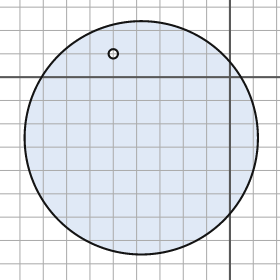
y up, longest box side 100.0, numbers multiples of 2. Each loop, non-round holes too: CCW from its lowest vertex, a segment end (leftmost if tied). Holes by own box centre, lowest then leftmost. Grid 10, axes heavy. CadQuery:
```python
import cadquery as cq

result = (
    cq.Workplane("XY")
    .moveTo(-38.0, -26.0)
    .circle(50.0)
    .moveTo(-50.0, 10.0)
    .circle(2.0)
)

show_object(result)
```